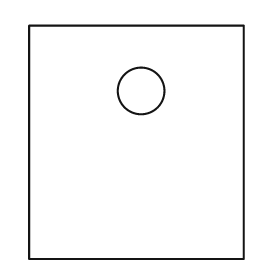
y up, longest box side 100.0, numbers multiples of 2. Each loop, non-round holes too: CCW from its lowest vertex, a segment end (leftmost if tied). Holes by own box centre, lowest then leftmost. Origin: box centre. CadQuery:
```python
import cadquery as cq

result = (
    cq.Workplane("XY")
    .moveTo(-46.0, -50.0)
    .lineTo(46.0, -50.0)
    .lineTo(46.0, 50.0)
    .lineTo(-46.0, 50.0)
    .close()
    .moveTo(2.0, 22.0)
    .circle(10.0)
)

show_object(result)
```